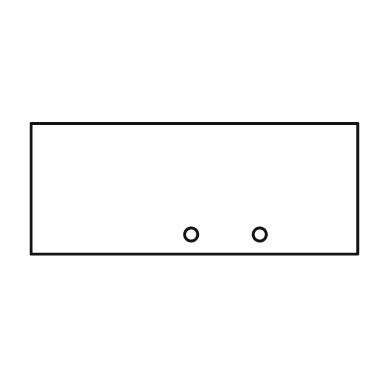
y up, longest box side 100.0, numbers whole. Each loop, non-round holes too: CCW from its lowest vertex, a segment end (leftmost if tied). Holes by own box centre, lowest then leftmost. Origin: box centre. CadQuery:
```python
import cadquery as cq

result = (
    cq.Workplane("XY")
    .moveTo(-50.0, -20.0)
    .lineTo(50.0, -20.0)
    .lineTo(50.0, 20.0)
    .lineTo(-50.0, 20.0)
    .close()
    .moveTo(-1.0, -14.0)
    .circle(2.0)
    .moveTo(20.0, -14.0)
    .circle(2.0)
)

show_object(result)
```